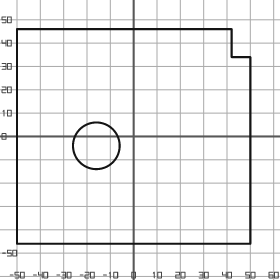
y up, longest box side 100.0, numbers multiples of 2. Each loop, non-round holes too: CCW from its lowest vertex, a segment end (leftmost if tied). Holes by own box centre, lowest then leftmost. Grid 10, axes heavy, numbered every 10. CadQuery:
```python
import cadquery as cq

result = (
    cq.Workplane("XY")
    .moveTo(-50.0, -46.0)
    .lineTo(50.0, -46.0)
    .lineTo(50.0, 34.0)
    .lineTo(42.0, 34.0)
    .lineTo(42.0, 46.0)
    .lineTo(-50.0, 46.0)
    .close()
    .moveTo(-16.0, -4.0)
    .circle(10.0)
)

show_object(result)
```